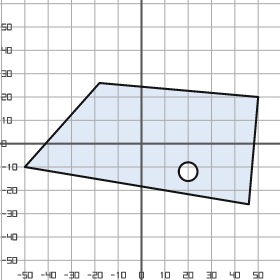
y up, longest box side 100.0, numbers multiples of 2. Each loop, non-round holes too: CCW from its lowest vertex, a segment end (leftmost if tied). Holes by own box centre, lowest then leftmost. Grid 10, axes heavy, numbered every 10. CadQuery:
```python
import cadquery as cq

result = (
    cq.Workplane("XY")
    .moveTo(46.0, -26.0)
    .lineTo(50.0, 20.0)
    .lineTo(-18.0, 26.0)
    .lineTo(-50.0, -10.0)
    .close()
    .moveTo(20.0, -12.0)
    .circle(4.0)
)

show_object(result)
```